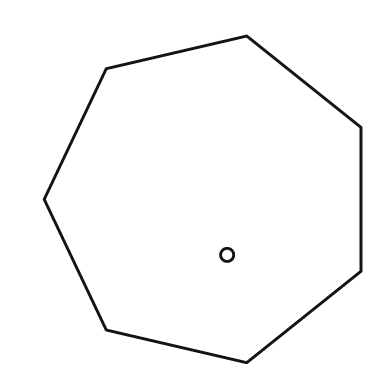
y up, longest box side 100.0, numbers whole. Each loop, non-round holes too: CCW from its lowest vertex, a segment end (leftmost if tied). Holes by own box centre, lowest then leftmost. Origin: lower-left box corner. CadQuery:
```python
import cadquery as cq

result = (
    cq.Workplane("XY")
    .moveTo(62.0, 0.0)
    .lineTo(97.0, 28.0)
    .lineTo(97.0, 72.0)
    .lineTo(62.0, 100.0)
    .lineTo(19.0, 90.0)
    .lineTo(0.0, 50.0)
    .lineTo(19.0, 10.0)
    .close()
    .moveTo(56.0, 33.0)
    .circle(2.0)
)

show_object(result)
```